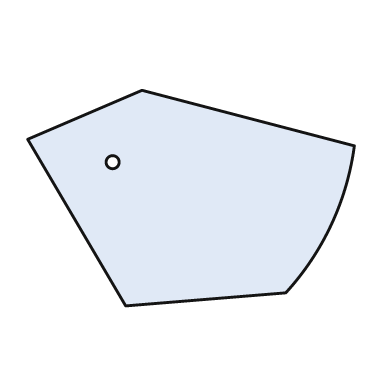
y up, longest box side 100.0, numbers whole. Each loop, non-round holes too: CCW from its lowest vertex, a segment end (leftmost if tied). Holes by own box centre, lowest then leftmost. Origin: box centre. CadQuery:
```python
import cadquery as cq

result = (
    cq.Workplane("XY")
    .moveTo(-20.0, -33.0)
    .lineTo(29.0, -29.0)
    .threePointArc((43.0, -8.0), (50.0, 16.0))
    .lineTo(-15.0, 33.0)
    .lineTo(-50.0, 18.0)
    .close()
    .moveTo(-24.0, 11.0)
    .circle(2.0)
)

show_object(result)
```